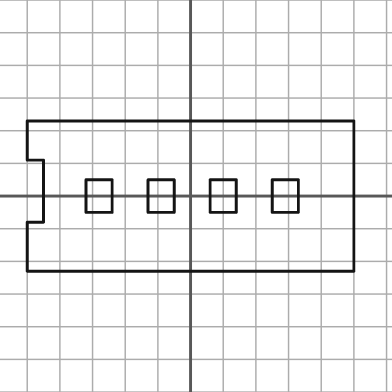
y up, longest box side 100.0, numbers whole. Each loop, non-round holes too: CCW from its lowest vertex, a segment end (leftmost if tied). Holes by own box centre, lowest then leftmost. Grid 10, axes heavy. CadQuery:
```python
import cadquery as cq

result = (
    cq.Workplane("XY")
    .moveTo(-50.0, -23.0)
    .lineTo(50.0, -23.0)
    .lineTo(50.0, 23.0)
    .lineTo(-50.0, 23.0)
    .lineTo(-50.0, 11.0)
    .lineTo(-45.0, 11.0)
    .lineTo(-45.0, -8.0)
    .lineTo(-50.0, -8.0)
    .close()
    .moveTo(-32.0, -5.0)
    .lineTo(-24.0, -5.0)
    .lineTo(-24.0, 5.0)
    .lineTo(-32.0, 5.0)
    .close()
    .moveTo(-13.0, -5.0)
    .lineTo(-5.0, -5.0)
    .lineTo(-5.0, 5.0)
    .lineTo(-13.0, 5.0)
    .close()
    .moveTo(6.0, -5.0)
    .lineTo(14.0, -5.0)
    .lineTo(14.0, 5.0)
    .lineTo(6.0, 5.0)
    .close()
    .moveTo(25.0, -5.0)
    .lineTo(33.0, -5.0)
    .lineTo(33.0, 5.0)
    .lineTo(25.0, 5.0)
    .close()
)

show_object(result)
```